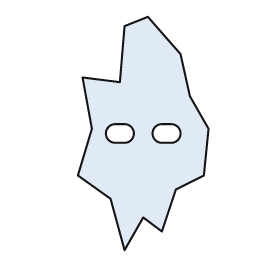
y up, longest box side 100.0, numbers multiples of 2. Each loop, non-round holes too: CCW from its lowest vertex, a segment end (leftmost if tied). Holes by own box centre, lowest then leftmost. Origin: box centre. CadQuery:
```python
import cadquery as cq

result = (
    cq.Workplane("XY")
    .moveTo(-8.0, -50.0)
    .lineTo(0.0, -36.0)
    .lineTo(8.0, -42.0)
    .lineTo(14.0, -24.0)
    .lineTo(26.0, -18.0)
    .lineTo(28.0, 2.0)
    .lineTo(20.0, 16.0)
    .lineTo(16.0, 34.0)
    .lineTo(2.0, 50.0)
    .lineTo(-8.0, 46.0)
    .lineTo(-10.0, 22.0)
    .lineTo(-26.0, 24.0)
    .lineTo(-22.0, 2.0)
    .lineTo(-28.0, -18.0)
    .lineTo(-14.0, -28.0)
    .close()
    .moveTo(-12.0, -4.0)
    .lineTo(-8.0, -4.0)
    .threePointArc((-4.0, 0.0), (-8.0, 4.0))
    .lineTo(-12.0, 4.0)
    .threePointArc((-16.0, 0.0), (-12.0, -4.0))
    .close()
    .moveTo(8.0, -4.0)
    .lineTo(12.0, -4.0)
    .threePointArc((16.0, 0.0), (12.0, 4.0))
    .lineTo(8.0, 4.0)
    .threePointArc((4.0, 0.0), (8.0, -4.0))
    .close()
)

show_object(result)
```